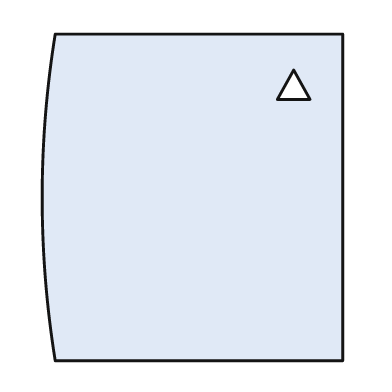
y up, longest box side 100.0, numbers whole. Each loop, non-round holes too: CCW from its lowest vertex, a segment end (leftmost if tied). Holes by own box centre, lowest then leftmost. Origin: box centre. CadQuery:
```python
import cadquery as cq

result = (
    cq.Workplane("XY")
    .moveTo(-42.0, -50.0)
    .lineTo(46.0, -50.0)
    .lineTo(46.0, 50.0)
    .lineTo(-42.0, 50.0)
    .threePointArc((-46.0, 0.0), (-42.0, -50.0))
    .close()
    .moveTo(26.0, 30.0)
    .lineTo(36.0, 30.0)
    .lineTo(31.0, 39.0)
    .close()
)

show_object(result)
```